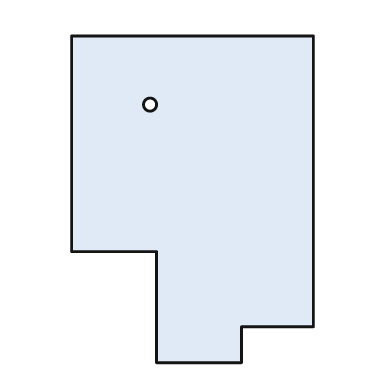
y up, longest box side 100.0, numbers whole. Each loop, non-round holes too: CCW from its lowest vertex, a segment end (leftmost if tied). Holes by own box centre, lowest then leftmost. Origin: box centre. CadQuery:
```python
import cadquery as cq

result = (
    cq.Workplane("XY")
    .moveTo(-11.0, -50.0)
    .lineTo(15.0, -50.0)
    .lineTo(15.0, -39.0)
    .lineTo(37.0, -39.0)
    .lineTo(37.0, 50.0)
    .lineTo(-37.0, 50.0)
    .lineTo(-37.0, -16.0)
    .lineTo(-11.0, -16.0)
    .close()
    .moveTo(-13.0, 29.0)
    .circle(2.0)
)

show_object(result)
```